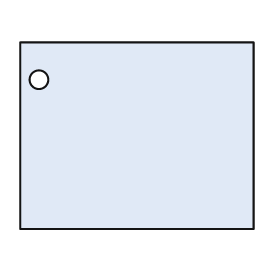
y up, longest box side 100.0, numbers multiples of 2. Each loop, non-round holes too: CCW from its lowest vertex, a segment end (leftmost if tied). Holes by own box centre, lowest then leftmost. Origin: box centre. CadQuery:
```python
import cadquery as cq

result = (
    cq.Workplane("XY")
    .moveTo(-50.0, -40.0)
    .lineTo(50.0, -40.0)
    .lineTo(50.0, 40.0)
    .lineTo(-50.0, 40.0)
    .close()
    .moveTo(-42.0, 24.0)
    .circle(4.0)
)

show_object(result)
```